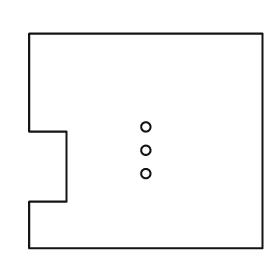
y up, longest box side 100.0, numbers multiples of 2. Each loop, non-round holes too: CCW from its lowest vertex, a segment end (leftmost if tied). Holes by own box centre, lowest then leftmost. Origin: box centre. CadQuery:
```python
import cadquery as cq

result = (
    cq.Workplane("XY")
    .moveTo(-50.0, -46.0)
    .lineTo(50.0, -46.0)
    .lineTo(50.0, 46.0)
    .lineTo(-50.0, 46.0)
    .lineTo(-50.0, 4.0)
    .lineTo(-34.0, 4.0)
    .lineTo(-34.0, -26.0)
    .lineTo(-50.0, -26.0)
    .close()
    .moveTo(0.0, -14.0)
    .circle(2.0)
    .moveTo(0.0, -4.0)
    .circle(2.0)
    .moveTo(0.0, 6.0)
    .circle(2.0)
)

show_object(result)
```